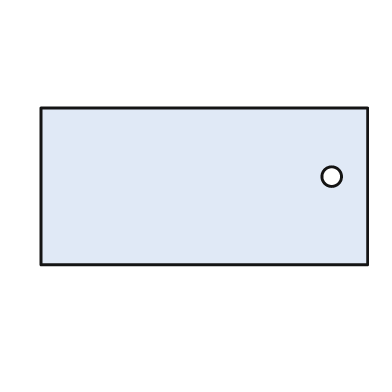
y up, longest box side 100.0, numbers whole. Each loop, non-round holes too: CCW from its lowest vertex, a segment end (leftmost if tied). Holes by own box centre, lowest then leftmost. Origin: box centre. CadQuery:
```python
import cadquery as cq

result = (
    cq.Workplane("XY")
    .moveTo(-50.0, -24.0)
    .lineTo(50.0, -24.0)
    .lineTo(50.0, 24.0)
    .lineTo(-50.0, 24.0)
    .close()
    .moveTo(39.0, 3.0)
    .circle(3.0)
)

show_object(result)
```